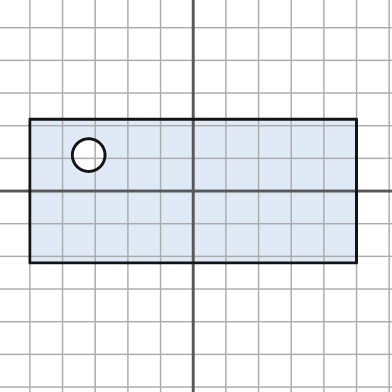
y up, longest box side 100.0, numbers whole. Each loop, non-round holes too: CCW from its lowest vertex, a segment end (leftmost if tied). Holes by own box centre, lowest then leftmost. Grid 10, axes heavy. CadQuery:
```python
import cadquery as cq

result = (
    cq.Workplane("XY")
    .moveTo(-50.0, -22.0)
    .lineTo(50.0, -22.0)
    .lineTo(50.0, 22.0)
    .lineTo(-50.0, 22.0)
    .close()
    .moveTo(-32.0, 11.0)
    .circle(5.0)
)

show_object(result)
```